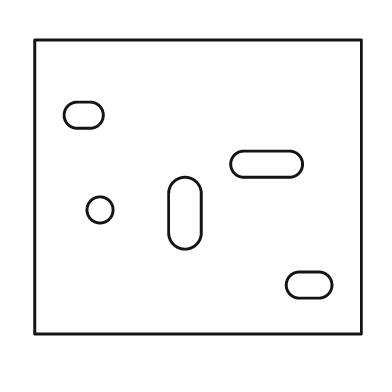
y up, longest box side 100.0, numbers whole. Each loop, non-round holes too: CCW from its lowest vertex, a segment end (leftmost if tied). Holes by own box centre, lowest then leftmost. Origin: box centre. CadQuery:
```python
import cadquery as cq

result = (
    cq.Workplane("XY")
    .moveTo(-50.0, -45.0)
    .lineTo(50.0, -45.0)
    .lineTo(50.0, 45.0)
    .lineTo(-50.0, 45.0)
    .close()
    .moveTo(31.0, -34.0)
    .lineTo(37.0, -34.0)
    .threePointArc((41.0, -30.0), (37.0, -26.0))
    .lineTo(31.0, -26.0)
    .threePointArc((27.0, -30.0), (31.0, -34.0))
    .close()
    .moveTo(-9.0, -14.0)
    .threePointArc((-4.0, -19.0), (1.0, -14.0))
    .lineTo(1.0, -2.0)
    .threePointArc((-4.0, 3.0), (-9.0, -2.0))
    .close()
    .moveTo(-30.0, -7.0)
    .circle(4.0)
    .moveTo(14.0, 3.0)
    .lineTo(28.0, 3.0)
    .threePointArc((32.0, 7.0), (28.0, 11.0))
    .lineTo(14.0, 11.0)
    .threePointArc((10.0, 7.0), (14.0, 3.0))
    .close()
    .moveTo(-37.0, 18.0)
    .lineTo(-33.0, 18.0)
    .threePointArc((-29.0, 22.0), (-33.0, 26.0))
    .lineTo(-37.0, 26.0)
    .threePointArc((-41.0, 22.0), (-37.0, 18.0))
    .close()
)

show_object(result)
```